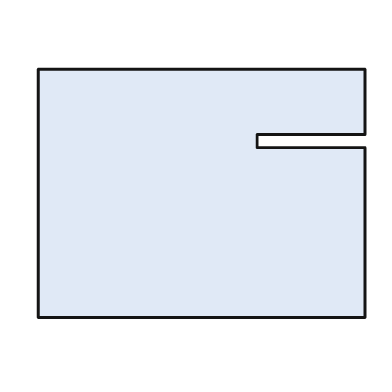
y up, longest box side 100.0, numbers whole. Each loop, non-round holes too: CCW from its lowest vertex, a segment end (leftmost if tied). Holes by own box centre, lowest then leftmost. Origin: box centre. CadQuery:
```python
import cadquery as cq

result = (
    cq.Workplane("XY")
    .moveTo(-50.0, -38.0)
    .lineTo(50.0, -38.0)
    .lineTo(50.0, 14.0)
    .lineTo(17.0, 14.0)
    .lineTo(17.0, 18.0)
    .lineTo(50.0, 18.0)
    .lineTo(50.0, 38.0)
    .lineTo(-50.0, 38.0)
    .close()
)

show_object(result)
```